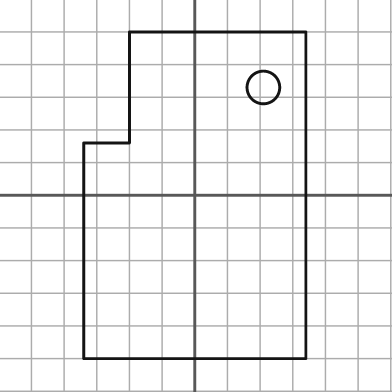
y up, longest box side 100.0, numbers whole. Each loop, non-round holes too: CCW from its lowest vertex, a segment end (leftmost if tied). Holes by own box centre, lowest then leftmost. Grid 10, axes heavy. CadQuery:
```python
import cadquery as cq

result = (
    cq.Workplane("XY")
    .moveTo(-34.0, -50.0)
    .lineTo(34.0, -50.0)
    .lineTo(34.0, 50.0)
    .lineTo(-20.0, 50.0)
    .lineTo(-20.0, 16.0)
    .lineTo(-34.0, 16.0)
    .close()
    .moveTo(21.0, 33.0)
    .circle(5.0)
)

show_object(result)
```